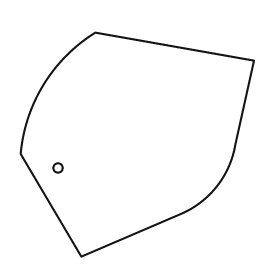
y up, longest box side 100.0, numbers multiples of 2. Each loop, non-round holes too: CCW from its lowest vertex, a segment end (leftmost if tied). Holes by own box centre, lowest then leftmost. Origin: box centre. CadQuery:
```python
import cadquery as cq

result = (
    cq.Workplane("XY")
    .moveTo(-24.0, -48.0)
    .lineTo(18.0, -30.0)
    .threePointArc((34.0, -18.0), (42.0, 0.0))
    .lineTo(50.0, 36.0)
    .lineTo(-18.0, 48.0)
    .threePointArc((-40.0, 26.0), (-50.0, -4.0))
    .close()
    .moveTo(-34.0, -10.0)
    .circle(2.0)
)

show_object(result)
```